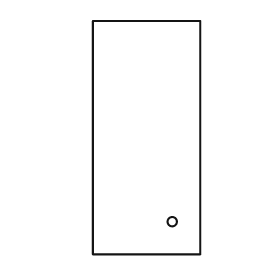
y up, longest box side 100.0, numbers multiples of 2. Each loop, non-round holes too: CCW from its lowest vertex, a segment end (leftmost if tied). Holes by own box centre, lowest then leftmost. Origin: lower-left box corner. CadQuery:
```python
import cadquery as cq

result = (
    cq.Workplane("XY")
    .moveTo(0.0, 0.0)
    .lineTo(46.0, 0.0)
    .lineTo(46.0, 100.0)
    .lineTo(0.0, 100.0)
    .close()
    .moveTo(34.0, 14.0)
    .circle(2.0)
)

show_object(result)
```